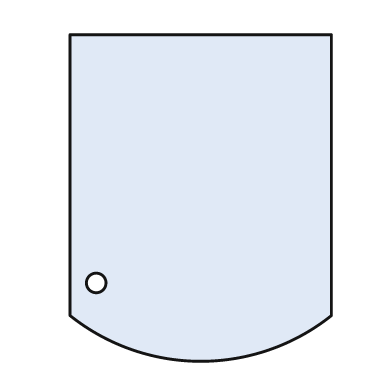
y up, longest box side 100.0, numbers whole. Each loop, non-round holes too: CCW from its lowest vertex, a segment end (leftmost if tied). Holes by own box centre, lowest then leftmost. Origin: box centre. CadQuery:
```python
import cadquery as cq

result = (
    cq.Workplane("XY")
    .moveTo(-40.0, -36.0)
    .threePointArc((0.0, -50.0), (40.0, -36.0))
    .lineTo(40.0, 50.0)
    .lineTo(-40.0, 50.0)
    .close()
    .moveTo(-32.0, -26.0)
    .circle(3.0)
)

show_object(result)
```